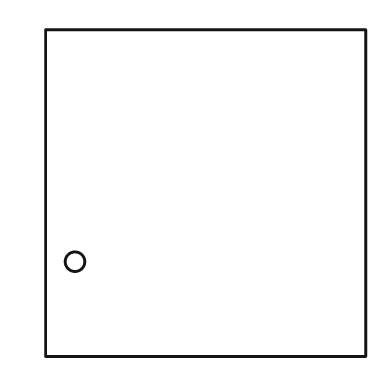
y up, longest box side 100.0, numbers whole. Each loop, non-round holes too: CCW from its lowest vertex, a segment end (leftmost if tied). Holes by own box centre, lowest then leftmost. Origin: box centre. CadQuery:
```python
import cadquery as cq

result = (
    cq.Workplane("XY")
    .moveTo(-49.0, -50.0)
    .lineTo(49.0, -50.0)
    .lineTo(49.0, 50.0)
    .lineTo(-49.0, 50.0)
    .close()
    .moveTo(-40.0, -21.0)
    .circle(3.0)
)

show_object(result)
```